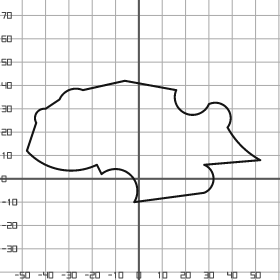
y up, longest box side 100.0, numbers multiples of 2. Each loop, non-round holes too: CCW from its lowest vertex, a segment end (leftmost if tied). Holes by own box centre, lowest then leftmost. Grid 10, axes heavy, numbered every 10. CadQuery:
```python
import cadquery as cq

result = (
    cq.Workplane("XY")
    .moveTo(-2.0, -10.0)
    .lineTo(28.0, -6.0)
    .threePointArc((32.0, 0.0), (28.0, 6.0))
    .lineTo(52.0, 8.0)
    .threePointArc((44.0, 14.0), (38.0, 22.0))
    .threePointArc((38.0, 30.0), (30.0, 32.0))
    .threePointArc((20.0, 28.0), (16.0, 38.0))
    .lineTo(-6.0, 42.0)
    .lineTo(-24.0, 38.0)
    .threePointArc((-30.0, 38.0), (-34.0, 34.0))
    .lineTo(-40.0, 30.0)
    .threePointArc((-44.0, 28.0), (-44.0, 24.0))
    .lineTo(-48.0, 12.0)
    .threePointArc((-34.0, 4.0), (-18.0, 6.0))
    .lineTo(-16.0, 2.0)
    .threePointArc((-4.0, 2.0), (-2.0, -10.0))
    .close()
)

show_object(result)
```